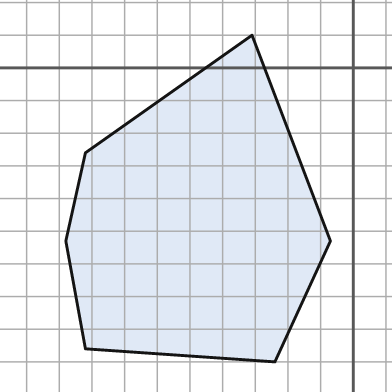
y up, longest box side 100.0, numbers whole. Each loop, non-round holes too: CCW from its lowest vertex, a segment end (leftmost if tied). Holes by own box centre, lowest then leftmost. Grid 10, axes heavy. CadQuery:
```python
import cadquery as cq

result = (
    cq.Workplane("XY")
    .moveTo(-24.0, -90.0)
    .lineTo(-7.0, -53.0)
    .lineTo(-31.0, 10.0)
    .lineTo(-82.0, -26.0)
    .lineTo(-88.0, -53.0)
    .lineTo(-82.0, -86.0)
    .close()
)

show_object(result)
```